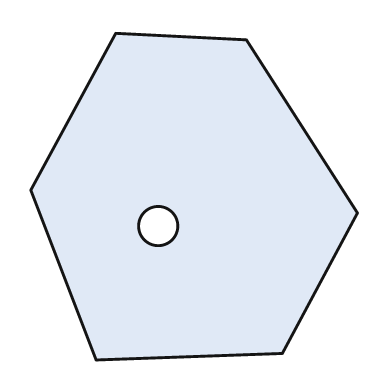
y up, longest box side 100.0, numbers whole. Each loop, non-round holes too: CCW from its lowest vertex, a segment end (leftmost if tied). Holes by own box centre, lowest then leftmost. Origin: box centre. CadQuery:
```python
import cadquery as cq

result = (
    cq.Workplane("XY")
    .moveTo(-30.0, -50.0)
    .lineTo(27.0, -48.0)
    .lineTo(50.0, -5.0)
    .lineTo(16.0, 48.0)
    .lineTo(-24.0, 50.0)
    .lineTo(-50.0, 2.0)
    .close()
    .moveTo(-11.0, -9.0)
    .circle(6.0)
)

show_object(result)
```